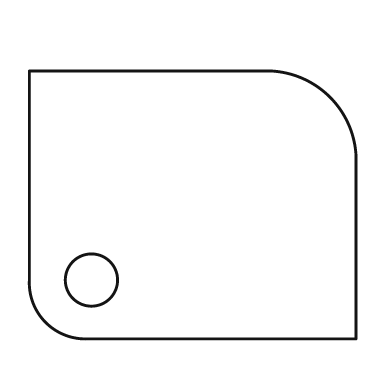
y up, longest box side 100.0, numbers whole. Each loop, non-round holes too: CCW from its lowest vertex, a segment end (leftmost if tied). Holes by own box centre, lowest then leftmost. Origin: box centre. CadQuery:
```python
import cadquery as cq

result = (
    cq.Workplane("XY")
    .moveTo(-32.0, -41.0)
    .lineTo(50.0, -41.0)
    .lineTo(50.0, 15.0)
    .threePointArc((42.0, 33.0), (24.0, 41.0))
    .lineTo(-50.0, 41.0)
    .lineTo(-50.0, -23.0)
    .threePointArc((-45.0, -36.0), (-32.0, -41.0))
    .close()
    .moveTo(-31.0, -23.0)
    .circle(8.0)
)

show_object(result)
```